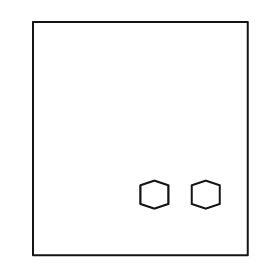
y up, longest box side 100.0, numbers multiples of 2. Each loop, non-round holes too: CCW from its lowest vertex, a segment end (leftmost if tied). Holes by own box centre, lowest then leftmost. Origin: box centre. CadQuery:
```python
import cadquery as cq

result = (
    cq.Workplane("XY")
    .moveTo(-46.0, -50.0)
    .lineTo(46.0, -50.0)
    .lineTo(46.0, 50.0)
    .lineTo(-46.0, 50.0)
    .close()
    .moveTo(6.0, -30.0)
    .lineTo(12.0, -28.0)
    .lineTo(12.0, -20.0)
    .lineTo(6.0, -18.0)
    .lineTo(0.0, -20.0)
    .lineTo(0.0, -28.0)
    .close()
    .moveTo(28.0, -30.0)
    .lineTo(34.0, -28.0)
    .lineTo(34.0, -20.0)
    .lineTo(28.0, -18.0)
    .lineTo(22.0, -20.0)
    .lineTo(22.0, -28.0)
    .close()
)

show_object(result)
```